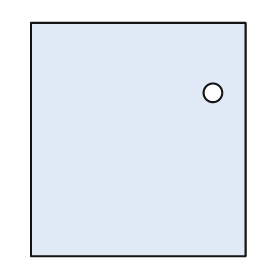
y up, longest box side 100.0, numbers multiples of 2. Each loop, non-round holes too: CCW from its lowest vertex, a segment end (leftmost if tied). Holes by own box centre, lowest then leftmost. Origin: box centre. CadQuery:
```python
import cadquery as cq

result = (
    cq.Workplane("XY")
    .moveTo(-46.0, -50.0)
    .lineTo(46.0, -50.0)
    .lineTo(46.0, 50.0)
    .lineTo(-46.0, 50.0)
    .close()
    .moveTo(32.0, 20.0)
    .circle(4.0)
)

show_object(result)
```